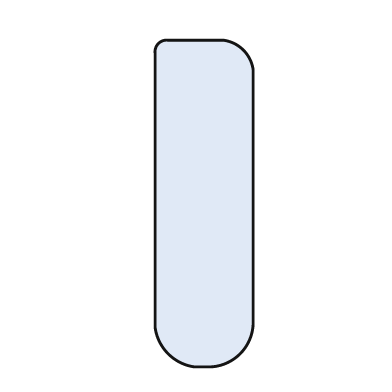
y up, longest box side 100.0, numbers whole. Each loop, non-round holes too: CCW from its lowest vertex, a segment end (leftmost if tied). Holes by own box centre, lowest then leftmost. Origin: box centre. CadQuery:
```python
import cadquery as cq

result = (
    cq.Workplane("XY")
    .moveTo(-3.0, -50.0)
    .lineTo(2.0, -50.0)
    .threePointArc((11.0, -46.0), (15.0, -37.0))
    .lineTo(15.0, 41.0)
    .threePointArc((12.0, 47.0), (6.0, 50.0))
    .lineTo(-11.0, 50.0)
    .threePointArc((-14.0, 49.0), (-15.0, 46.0))
    .lineTo(-15.0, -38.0)
    .threePointArc((-11.0, -46.0), (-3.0, -50.0))
    .close()
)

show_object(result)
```